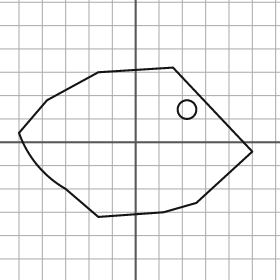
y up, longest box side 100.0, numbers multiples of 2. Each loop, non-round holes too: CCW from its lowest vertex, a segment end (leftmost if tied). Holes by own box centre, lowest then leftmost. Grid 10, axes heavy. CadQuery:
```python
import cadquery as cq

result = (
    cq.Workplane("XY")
    .moveTo(-16.0, -32.0)
    .lineTo(12.0, -30.0)
    .lineTo(26.0, -26.0)
    .lineTo(50.0, -4.0)
    .lineTo(16.0, 32.0)
    .lineTo(-16.0, 30.0)
    .lineTo(-38.0, 18.0)
    .lineTo(-50.0, 4.0)
    .threePointArc((-42.0, -10.0), (-30.0, -20.0))
    .close()
    .moveTo(22.0, 14.0)
    .circle(4.0)
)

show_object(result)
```